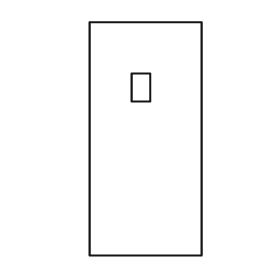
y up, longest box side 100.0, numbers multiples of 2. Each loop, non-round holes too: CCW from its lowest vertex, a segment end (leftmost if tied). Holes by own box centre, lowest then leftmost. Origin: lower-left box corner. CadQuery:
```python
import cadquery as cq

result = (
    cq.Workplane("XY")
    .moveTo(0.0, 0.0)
    .lineTo(48.0, 0.0)
    .lineTo(48.0, 100.0)
    .lineTo(0.0, 100.0)
    .close()
    .moveTo(18.0, 66.0)
    .lineTo(26.0, 66.0)
    .lineTo(26.0, 78.0)
    .lineTo(18.0, 78.0)
    .close()
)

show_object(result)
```